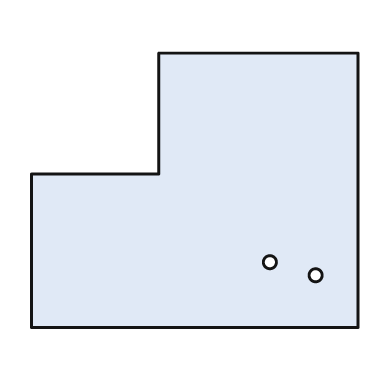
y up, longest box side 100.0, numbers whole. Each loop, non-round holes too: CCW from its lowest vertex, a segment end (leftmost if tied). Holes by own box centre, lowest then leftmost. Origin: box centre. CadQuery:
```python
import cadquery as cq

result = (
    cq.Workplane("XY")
    .moveTo(-50.0, -42.0)
    .lineTo(50.0, -42.0)
    .lineTo(50.0, 42.0)
    .lineTo(-11.0, 42.0)
    .lineTo(-11.0, 5.0)
    .lineTo(-50.0, 5.0)
    .close()
    .moveTo(37.0, -26.0)
    .circle(2.0)
    .moveTo(23.0, -22.0)
    .circle(2.0)
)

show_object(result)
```